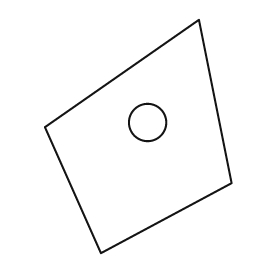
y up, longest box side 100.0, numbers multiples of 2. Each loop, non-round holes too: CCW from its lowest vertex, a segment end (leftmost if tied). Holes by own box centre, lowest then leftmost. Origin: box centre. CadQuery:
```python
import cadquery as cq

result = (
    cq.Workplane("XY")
    .moveTo(-16.0, -50.0)
    .lineTo(40.0, -20.0)
    .lineTo(26.0, 50.0)
    .lineTo(-40.0, 4.0)
    .close()
    .moveTo(4.0, 6.0)
    .circle(8.0)
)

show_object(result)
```